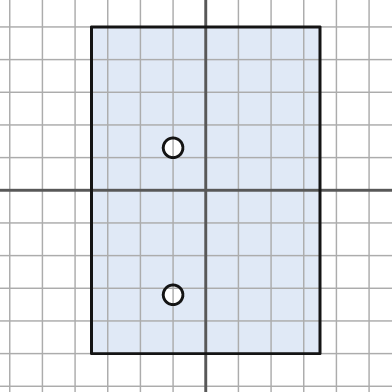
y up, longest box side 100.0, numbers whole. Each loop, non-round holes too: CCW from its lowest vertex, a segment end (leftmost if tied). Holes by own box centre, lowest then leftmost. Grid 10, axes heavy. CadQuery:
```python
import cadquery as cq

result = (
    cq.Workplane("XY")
    .moveTo(-35.0, -50.0)
    .lineTo(35.0, -50.0)
    .lineTo(35.0, 50.0)
    .lineTo(-35.0, 50.0)
    .close()
    .moveTo(-10.0, -32.0)
    .circle(3.0)
    .moveTo(-10.0, 13.0)
    .circle(3.0)
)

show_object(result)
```